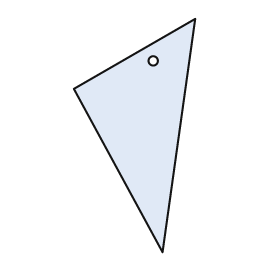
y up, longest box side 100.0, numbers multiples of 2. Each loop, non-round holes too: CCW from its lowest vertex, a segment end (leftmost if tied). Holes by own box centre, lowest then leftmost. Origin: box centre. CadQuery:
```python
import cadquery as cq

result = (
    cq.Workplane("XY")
    .moveTo(12.0, -50.0)
    .lineTo(26.0, 50.0)
    .lineTo(-26.0, 20.0)
    .close()
    .moveTo(8.0, 32.0)
    .circle(2.0)
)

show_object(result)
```